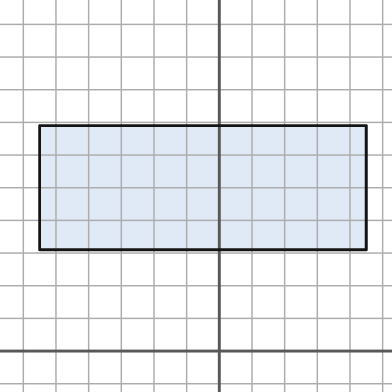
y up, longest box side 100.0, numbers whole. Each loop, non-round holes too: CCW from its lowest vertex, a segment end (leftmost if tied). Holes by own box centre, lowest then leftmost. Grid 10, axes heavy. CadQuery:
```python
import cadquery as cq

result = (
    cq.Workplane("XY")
    .moveTo(-55.0, 31.0)
    .lineTo(45.0, 31.0)
    .lineTo(45.0, 69.0)
    .lineTo(-55.0, 69.0)
    .close()
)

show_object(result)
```